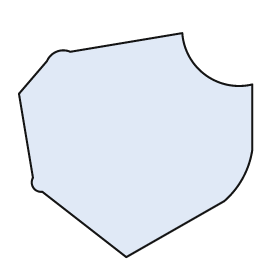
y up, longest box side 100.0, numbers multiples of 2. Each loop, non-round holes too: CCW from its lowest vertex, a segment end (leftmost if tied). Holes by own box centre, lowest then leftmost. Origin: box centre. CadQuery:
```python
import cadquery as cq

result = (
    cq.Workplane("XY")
    .moveTo(-4.0, -48.0)
    .lineTo(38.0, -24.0)
    .threePointArc((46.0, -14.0), (50.0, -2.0))
    .lineTo(50.0, 26.0)
    .threePointArc((30.0, 30.0), (20.0, 48.0))
    .lineTo(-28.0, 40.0)
    .threePointArc((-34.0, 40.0), (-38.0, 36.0))
    .lineTo(-50.0, 22.0)
    .lineTo(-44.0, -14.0)
    .threePointArc((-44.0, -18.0), (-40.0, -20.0))
    .close()
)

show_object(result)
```